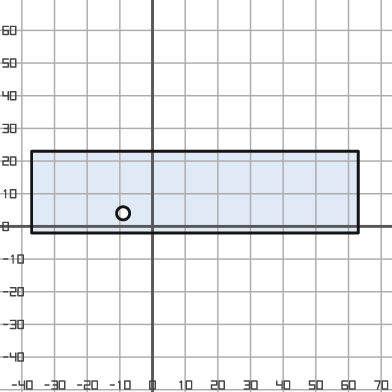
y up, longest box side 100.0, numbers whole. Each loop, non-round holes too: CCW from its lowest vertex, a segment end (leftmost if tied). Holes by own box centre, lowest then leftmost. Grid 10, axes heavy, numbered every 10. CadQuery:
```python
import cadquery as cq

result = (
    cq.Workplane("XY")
    .moveTo(-37.0, -2.0)
    .lineTo(63.0, -2.0)
    .lineTo(63.0, 23.0)
    .lineTo(-37.0, 23.0)
    .close()
    .moveTo(-9.0, 4.0)
    .circle(2.0)
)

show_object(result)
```